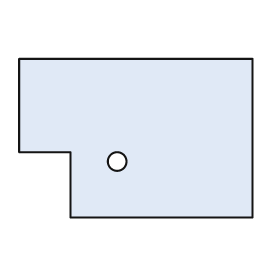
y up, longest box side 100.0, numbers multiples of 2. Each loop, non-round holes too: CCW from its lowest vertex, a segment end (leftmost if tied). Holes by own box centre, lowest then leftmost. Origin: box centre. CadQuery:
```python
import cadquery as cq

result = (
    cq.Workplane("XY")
    .moveTo(-28.0, -34.0)
    .lineTo(50.0, -34.0)
    .lineTo(50.0, 34.0)
    .lineTo(-50.0, 34.0)
    .lineTo(-50.0, -6.0)
    .lineTo(-28.0, -6.0)
    .close()
    .moveTo(-8.0, -10.0)
    .circle(4.0)
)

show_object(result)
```